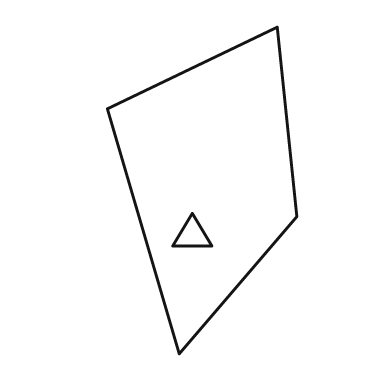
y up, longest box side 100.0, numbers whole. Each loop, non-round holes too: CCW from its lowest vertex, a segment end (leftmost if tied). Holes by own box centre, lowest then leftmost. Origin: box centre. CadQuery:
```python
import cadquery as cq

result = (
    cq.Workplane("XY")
    .moveTo(-7.0, -50.0)
    .lineTo(29.0, -8.0)
    .lineTo(23.0, 50.0)
    .lineTo(-29.0, 25.0)
    .close()
    .moveTo(-9.0, -17.0)
    .lineTo(3.0, -17.0)
    .lineTo(-3.0, -7.0)
    .close()
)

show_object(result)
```